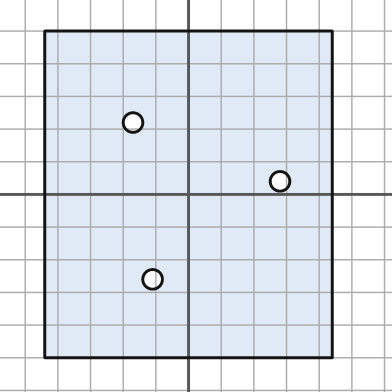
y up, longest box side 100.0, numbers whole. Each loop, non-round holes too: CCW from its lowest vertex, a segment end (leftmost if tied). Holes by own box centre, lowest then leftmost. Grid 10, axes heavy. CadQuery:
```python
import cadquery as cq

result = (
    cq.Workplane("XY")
    .moveTo(-44.0, -50.0)
    .lineTo(44.0, -50.0)
    .lineTo(44.0, 50.0)
    .lineTo(-44.0, 50.0)
    .close()
    .moveTo(-11.0, -26.0)
    .circle(3.0)
    .moveTo(28.0, 4.0)
    .circle(3.0)
    .moveTo(-17.0, 22.0)
    .circle(3.0)
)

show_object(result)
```